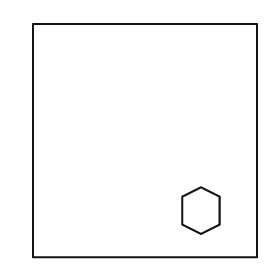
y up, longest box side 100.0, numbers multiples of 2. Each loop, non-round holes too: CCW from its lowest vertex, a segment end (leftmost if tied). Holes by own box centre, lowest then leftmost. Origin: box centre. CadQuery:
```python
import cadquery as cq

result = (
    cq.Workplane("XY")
    .moveTo(-48.0, -50.0)
    .lineTo(48.0, -50.0)
    .lineTo(48.0, 50.0)
    .lineTo(-48.0, 50.0)
    .close()
    .moveTo(24.0, -40.0)
    .lineTo(32.0, -36.0)
    .lineTo(32.0, -24.0)
    .lineTo(24.0, -20.0)
    .lineTo(16.0, -24.0)
    .lineTo(16.0, -36.0)
    .close()
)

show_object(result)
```